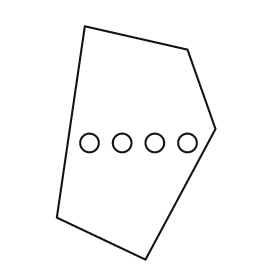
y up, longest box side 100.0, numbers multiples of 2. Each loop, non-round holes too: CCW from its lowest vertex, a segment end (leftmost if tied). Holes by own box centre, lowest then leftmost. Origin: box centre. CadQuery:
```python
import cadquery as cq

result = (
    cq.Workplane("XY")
    .moveTo(4.0, -50.0)
    .lineTo(34.0, 6.0)
    .lineTo(22.0, 40.0)
    .lineTo(-22.0, 50.0)
    .lineTo(-34.0, -32.0)
    .close()
    .moveTo(-20.0, 0.0)
    .circle(4.0)
    .moveTo(-6.0, 0.0)
    .circle(4.0)
    .moveTo(8.0, 0.0)
    .circle(4.0)
    .moveTo(22.0, 0.0)
    .circle(4.0)
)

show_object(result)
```